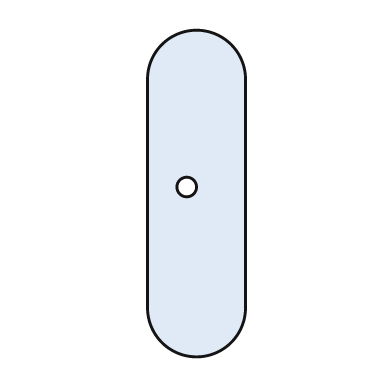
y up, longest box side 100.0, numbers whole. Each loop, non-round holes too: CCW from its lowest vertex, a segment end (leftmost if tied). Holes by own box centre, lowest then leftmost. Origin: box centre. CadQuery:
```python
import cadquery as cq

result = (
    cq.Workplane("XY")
    .moveTo(-15.0, -35.0)
    .threePointArc((0.0, -50.0), (15.0, -35.0))
    .lineTo(15.0, 35.0)
    .threePointArc((0.0, 50.0), (-15.0, 35.0))
    .close()
    .moveTo(-3.0, 2.0)
    .circle(3.0)
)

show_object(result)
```